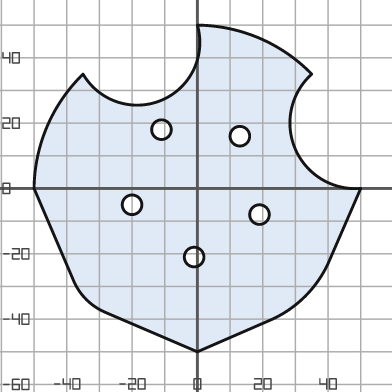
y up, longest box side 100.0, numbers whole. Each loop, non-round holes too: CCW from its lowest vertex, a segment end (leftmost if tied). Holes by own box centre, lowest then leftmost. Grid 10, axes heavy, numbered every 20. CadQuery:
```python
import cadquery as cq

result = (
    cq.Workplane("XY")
    .moveTo(0.0, -50.0)
    .lineTo(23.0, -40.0)
    .threePointArc((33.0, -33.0), (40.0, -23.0))
    .lineTo(50.0, 0.0)
    .threePointArc((30.0, 12.0), (35.0, 35.0))
    .threePointArc((19.0, 46.0), (0.0, 50.0))
    .threePointArc((-11.0, 27.0), (-35.0, 35.0))
    .threePointArc((-46.0, 19.0), (-50.0, 0.0))
    .lineTo(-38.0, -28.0)
    .threePointArc((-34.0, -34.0), (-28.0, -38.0))
    .close()
    .moveTo(-1.0, -21.0)
    .circle(3.0)
    .moveTo(19.0, -8.0)
    .circle(3.0)
    .moveTo(-20.0, -5.0)
    .circle(3.0)
    .moveTo(13.0, 16.0)
    .circle(3.0)
    .moveTo(-11.0, 18.0)
    .circle(3.0)
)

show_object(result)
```